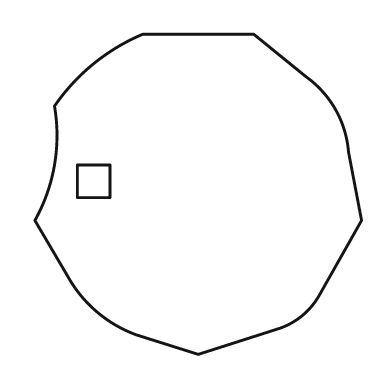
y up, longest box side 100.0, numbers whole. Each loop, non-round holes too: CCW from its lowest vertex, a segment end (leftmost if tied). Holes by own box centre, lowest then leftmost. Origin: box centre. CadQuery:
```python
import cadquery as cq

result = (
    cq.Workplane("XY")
    .moveTo(0.0, -49.0)
    .lineTo(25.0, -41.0)
    .threePointArc((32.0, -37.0), (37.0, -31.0))
    .lineTo(50.0, -8.0)
    .lineTo(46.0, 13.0)
    .threePointArc((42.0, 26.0), (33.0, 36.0))
    .lineTo(17.0, 49.0)
    .lineTo(-17.0, 49.0)
    .threePointArc((-32.0, 40.0), (-44.0, 27.0))
    .threePointArc((-44.0, 9.0), (-50.0, -8.0))
    .lineTo(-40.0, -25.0)
    .threePointArc((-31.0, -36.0), (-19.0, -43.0))
    .close()
    .moveTo(-37.0, -1.0)
    .lineTo(-27.0, -1.0)
    .lineTo(-27.0, 9.0)
    .lineTo(-37.0, 9.0)
    .close()
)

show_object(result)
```